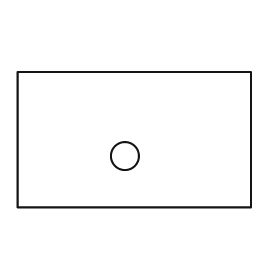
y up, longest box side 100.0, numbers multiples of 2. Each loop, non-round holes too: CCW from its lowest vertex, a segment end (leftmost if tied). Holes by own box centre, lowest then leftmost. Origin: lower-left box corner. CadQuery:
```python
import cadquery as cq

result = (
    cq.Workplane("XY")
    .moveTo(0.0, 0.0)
    .lineTo(100.0, 0.0)
    .lineTo(100.0, 58.0)
    .lineTo(0.0, 58.0)
    .close()
    .moveTo(46.0, 22.0)
    .circle(6.0)
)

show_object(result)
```